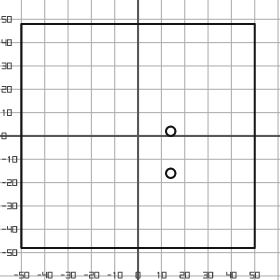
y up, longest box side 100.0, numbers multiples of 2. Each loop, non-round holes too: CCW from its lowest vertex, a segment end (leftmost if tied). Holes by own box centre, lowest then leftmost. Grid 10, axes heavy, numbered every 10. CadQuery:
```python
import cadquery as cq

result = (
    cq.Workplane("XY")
    .moveTo(-50.0, -48.0)
    .lineTo(50.0, -48.0)
    .lineTo(50.0, 48.0)
    .lineTo(-50.0, 48.0)
    .close()
    .moveTo(14.0, -16.0)
    .circle(2.0)
    .moveTo(14.0, 2.0)
    .circle(2.0)
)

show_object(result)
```